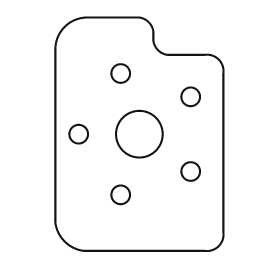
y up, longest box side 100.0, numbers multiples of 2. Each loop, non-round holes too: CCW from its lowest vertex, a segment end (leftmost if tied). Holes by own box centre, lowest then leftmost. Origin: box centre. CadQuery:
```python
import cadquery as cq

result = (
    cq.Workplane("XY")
    .moveTo(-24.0, -50.0)
    .lineTo(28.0, -50.0)
    .threePointArc((34.0, -48.0), (36.0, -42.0))
    .lineTo(36.0, 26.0)
    .threePointArc((34.0, 32.0), (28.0, 34.0))
    .lineTo(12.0, 34.0)
    .threePointArc((8.0, 36.0), (6.0, 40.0))
    .lineTo(6.0, 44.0)
    .threePointArc((4.0, 48.0), (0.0, 50.0))
    .lineTo(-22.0, 50.0)
    .threePointArc((-32.0, 46.0), (-36.0, 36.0))
    .lineTo(-36.0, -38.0)
    .threePointArc((-32.0, -46.0), (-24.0, -50.0))
    .close()
    .moveTo(-8.0, -26.0)
    .circle(4.0)
    .moveTo(22.0, -16.0)
    .circle(4.0)
    .moveTo(-26.0, 0.0)
    .circle(4.0)
    .moveTo(0.0, 0.0)
    .circle(10.0)
    .moveTo(22.0, 16.0)
    .circle(4.0)
    .moveTo(-8.0, 26.0)
    .circle(4.0)
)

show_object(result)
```